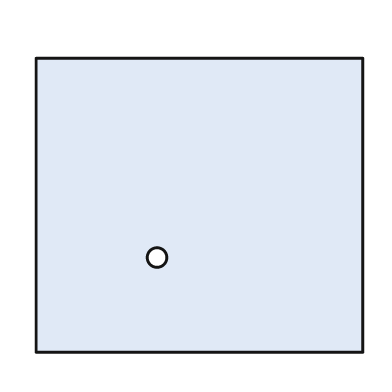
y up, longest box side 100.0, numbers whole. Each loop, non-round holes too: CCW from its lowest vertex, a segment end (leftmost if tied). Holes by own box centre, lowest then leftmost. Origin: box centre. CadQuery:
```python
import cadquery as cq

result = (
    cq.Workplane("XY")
    .moveTo(-50.0, -45.0)
    .lineTo(50.0, -45.0)
    .lineTo(50.0, 45.0)
    .lineTo(-50.0, 45.0)
    .close()
    .moveTo(-13.0, -16.0)
    .circle(3.0)
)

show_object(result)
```